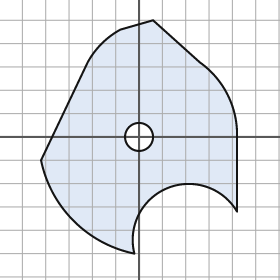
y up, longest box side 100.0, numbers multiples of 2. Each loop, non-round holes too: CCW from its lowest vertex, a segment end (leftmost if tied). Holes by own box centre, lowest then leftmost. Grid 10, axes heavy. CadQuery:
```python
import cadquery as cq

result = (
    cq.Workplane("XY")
    .moveTo(-2.0, -50.0)
    .threePointArc((12.0, -22.0), (42.0, -32.0))
    .lineTo(42.0, 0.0)
    .threePointArc((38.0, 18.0), (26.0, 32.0))
    .lineTo(6.0, 50.0)
    .lineTo(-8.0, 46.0)
    .threePointArc((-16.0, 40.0), (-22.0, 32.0))
    .lineTo(-42.0, -10.0)
    .threePointArc((-28.0, -36.0), (-2.0, -50.0))
    .close()
    .moveTo(0.0, 0.0)
    .circle(6.0)
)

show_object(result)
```